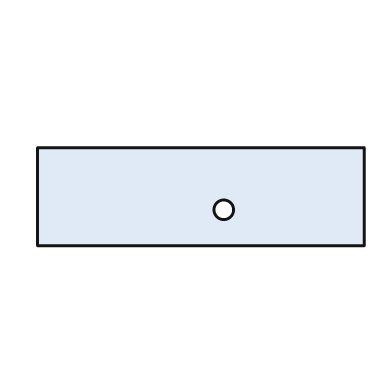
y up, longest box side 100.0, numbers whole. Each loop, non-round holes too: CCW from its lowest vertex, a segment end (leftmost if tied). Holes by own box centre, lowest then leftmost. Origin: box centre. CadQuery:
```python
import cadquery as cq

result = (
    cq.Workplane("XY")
    .moveTo(-50.0, -15.0)
    .lineTo(50.0, -15.0)
    .lineTo(50.0, 15.0)
    .lineTo(-50.0, 15.0)
    .close()
    .moveTo(7.0, -4.0)
    .circle(3.0)
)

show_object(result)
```